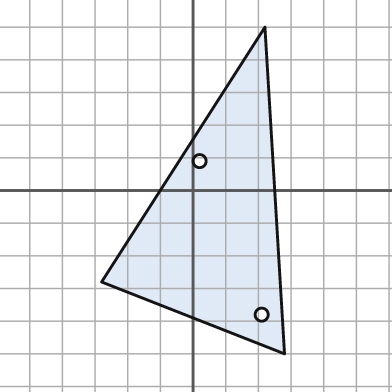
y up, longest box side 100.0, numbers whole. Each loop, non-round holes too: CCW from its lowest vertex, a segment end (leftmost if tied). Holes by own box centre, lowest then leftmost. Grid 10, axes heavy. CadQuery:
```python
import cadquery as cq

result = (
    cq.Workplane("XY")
    .moveTo(28.0, -50.0)
    .lineTo(22.0, 50.0)
    .lineTo(-28.0, -28.0)
    .close()
    .moveTo(21.0, -38.0)
    .circle(2.0)
    .moveTo(2.0, 9.0)
    .circle(2.0)
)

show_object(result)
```